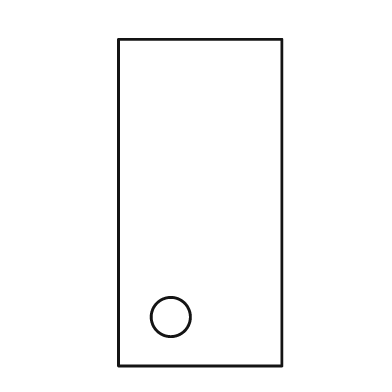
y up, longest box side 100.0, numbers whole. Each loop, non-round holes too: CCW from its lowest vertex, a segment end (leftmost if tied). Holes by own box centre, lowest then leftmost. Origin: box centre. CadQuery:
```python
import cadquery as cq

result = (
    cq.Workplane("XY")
    .moveTo(-25.0, -50.0)
    .lineTo(25.0, -50.0)
    .lineTo(25.0, 50.0)
    .lineTo(-25.0, 50.0)
    .close()
    .moveTo(-9.0, -35.0)
    .circle(6.0)
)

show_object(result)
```